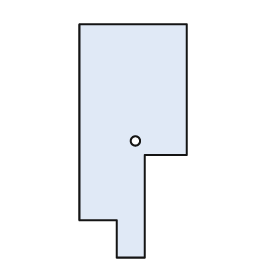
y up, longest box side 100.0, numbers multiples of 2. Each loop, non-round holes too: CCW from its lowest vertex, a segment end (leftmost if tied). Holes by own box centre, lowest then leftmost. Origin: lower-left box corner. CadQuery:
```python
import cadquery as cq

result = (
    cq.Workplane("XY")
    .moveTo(16.0, 0.0)
    .lineTo(28.0, 0.0)
    .lineTo(28.0, 44.0)
    .lineTo(46.0, 44.0)
    .lineTo(46.0, 100.0)
    .lineTo(0.0, 100.0)
    .lineTo(0.0, 16.0)
    .lineTo(16.0, 16.0)
    .close()
    .moveTo(24.0, 50.0)
    .circle(2.0)
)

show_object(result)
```